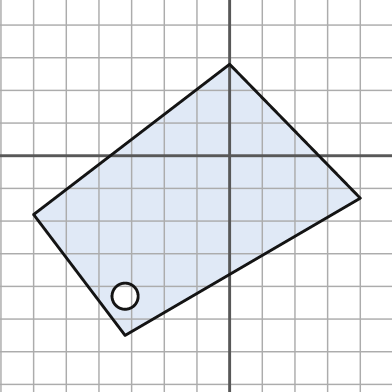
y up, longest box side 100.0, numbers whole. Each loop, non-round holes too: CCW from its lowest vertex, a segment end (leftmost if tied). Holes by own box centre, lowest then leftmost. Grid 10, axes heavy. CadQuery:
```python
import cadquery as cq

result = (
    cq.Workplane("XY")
    .moveTo(-32.0, -55.0)
    .lineTo(40.0, -13.0)
    .lineTo(0.0, 28.0)
    .lineTo(-60.0, -18.0)
    .close()
    .moveTo(-32.0, -43.0)
    .circle(4.0)
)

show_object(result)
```